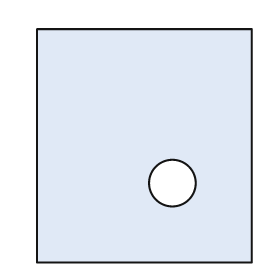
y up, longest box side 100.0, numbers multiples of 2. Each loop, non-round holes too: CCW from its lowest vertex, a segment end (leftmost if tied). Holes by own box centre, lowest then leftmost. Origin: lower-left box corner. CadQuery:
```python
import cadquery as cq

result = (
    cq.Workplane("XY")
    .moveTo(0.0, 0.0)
    .lineTo(92.0, 0.0)
    .lineTo(92.0, 100.0)
    .lineTo(0.0, 100.0)
    .close()
    .moveTo(58.0, 34.0)
    .circle(10.0)
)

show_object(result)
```